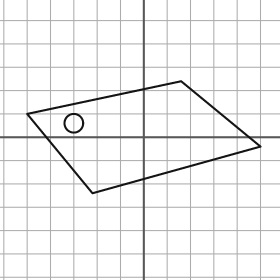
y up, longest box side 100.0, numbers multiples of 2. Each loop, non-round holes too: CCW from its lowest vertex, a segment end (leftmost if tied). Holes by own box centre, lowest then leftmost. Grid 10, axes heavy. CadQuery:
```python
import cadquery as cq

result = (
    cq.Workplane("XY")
    .moveTo(-22.0, -24.0)
    .lineTo(50.0, -4.0)
    .lineTo(16.0, 24.0)
    .lineTo(-50.0, 10.0)
    .close()
    .moveTo(-30.0, 6.0)
    .circle(4.0)
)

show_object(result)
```